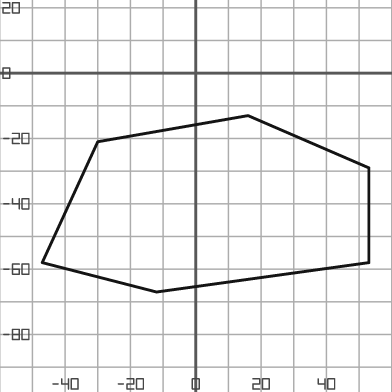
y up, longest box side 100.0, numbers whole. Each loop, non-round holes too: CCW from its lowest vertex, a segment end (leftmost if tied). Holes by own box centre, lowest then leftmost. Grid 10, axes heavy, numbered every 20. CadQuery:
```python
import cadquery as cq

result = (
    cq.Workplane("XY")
    .moveTo(-12.0, -67.0)
    .lineTo(53.0, -58.0)
    .lineTo(53.0, -29.0)
    .lineTo(16.0, -13.0)
    .lineTo(-30.0, -21.0)
    .lineTo(-47.0, -58.0)
    .close()
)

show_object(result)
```